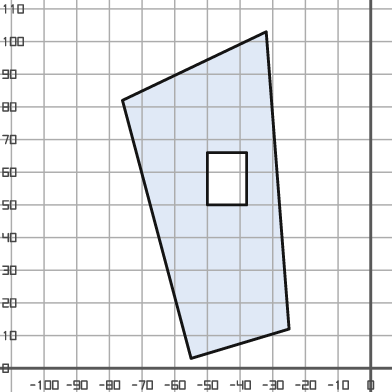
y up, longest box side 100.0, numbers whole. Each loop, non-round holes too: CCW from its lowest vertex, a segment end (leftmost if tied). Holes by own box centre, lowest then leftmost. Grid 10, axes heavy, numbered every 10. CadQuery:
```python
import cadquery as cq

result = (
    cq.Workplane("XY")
    .moveTo(-55.0, 3.0)
    .lineTo(-25.0, 12.0)
    .lineTo(-32.0, 103.0)
    .lineTo(-76.0, 82.0)
    .close()
    .moveTo(-50.0, 50.0)
    .lineTo(-38.0, 50.0)
    .lineTo(-38.0, 66.0)
    .lineTo(-50.0, 66.0)
    .close()
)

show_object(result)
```